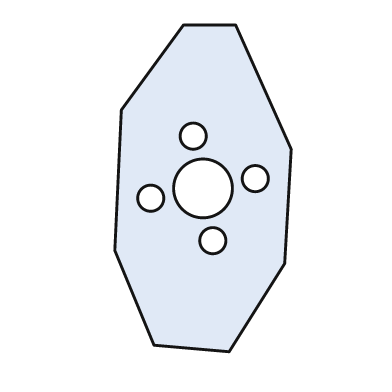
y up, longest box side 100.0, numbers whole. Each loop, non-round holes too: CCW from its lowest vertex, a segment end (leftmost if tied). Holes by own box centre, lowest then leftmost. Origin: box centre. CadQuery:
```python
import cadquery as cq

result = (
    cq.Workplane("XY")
    .moveTo(8.0, -50.0)
    .lineTo(25.0, -23.0)
    .lineTo(27.0, 12.0)
    .lineTo(10.0, 50.0)
    .lineTo(-6.0, 50.0)
    .lineTo(-25.0, 24.0)
    .lineTo(-27.0, -19.0)
    .lineTo(-15.0, -48.0)
    .close()
    .moveTo(3.0, -16.0)
    .circle(4.0)
    .moveTo(-16.0, -3.0)
    .circle(4.0)
    .moveTo(0.0, 0.0)
    .circle(9.0)
    .moveTo(16.0, 3.0)
    .circle(4.0)
    .moveTo(-3.0, 16.0)
    .circle(4.0)
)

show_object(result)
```